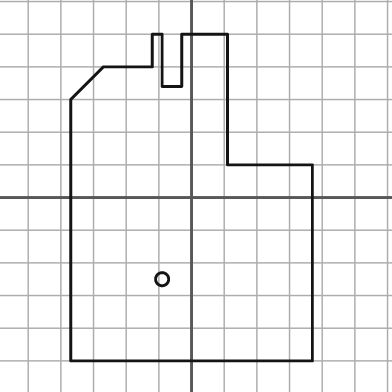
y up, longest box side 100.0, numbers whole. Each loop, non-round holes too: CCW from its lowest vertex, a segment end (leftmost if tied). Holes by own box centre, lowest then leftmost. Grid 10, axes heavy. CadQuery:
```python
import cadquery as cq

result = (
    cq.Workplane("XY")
    .moveTo(-37.0, -50.0)
    .lineTo(37.0, -50.0)
    .lineTo(37.0, 10.0)
    .lineTo(11.0, 10.0)
    .lineTo(11.0, 50.0)
    .lineTo(-3.0, 50.0)
    .lineTo(-3.0, 34.0)
    .lineTo(-9.0, 34.0)
    .lineTo(-9.0, 50.0)
    .lineTo(-12.0, 50.0)
    .lineTo(-12.0, 40.0)
    .lineTo(-27.0, 40.0)
    .lineTo(-37.0, 30.0)
    .close()
    .moveTo(-9.0, -25.0)
    .circle(2.0)
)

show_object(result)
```